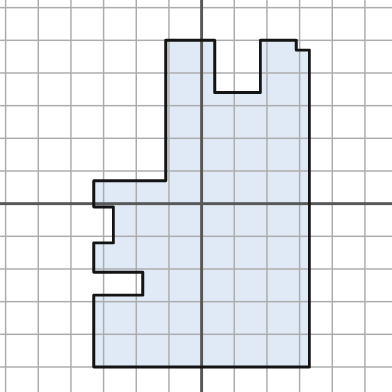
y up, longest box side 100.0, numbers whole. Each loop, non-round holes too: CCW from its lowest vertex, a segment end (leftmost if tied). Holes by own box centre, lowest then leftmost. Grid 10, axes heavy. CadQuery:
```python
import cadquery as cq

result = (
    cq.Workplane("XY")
    .moveTo(-33.0, -50.0)
    .lineTo(33.0, -50.0)
    .lineTo(33.0, 47.0)
    .lineTo(29.0, 47.0)
    .lineTo(29.0, 50.0)
    .lineTo(18.0, 50.0)
    .lineTo(18.0, 34.0)
    .lineTo(4.0, 34.0)
    .lineTo(4.0, 50.0)
    .lineTo(-11.0, 50.0)
    .lineTo(-11.0, 7.0)
    .lineTo(-33.0, 7.0)
    .lineTo(-33.0, -1.0)
    .lineTo(-27.0, -1.0)
    .lineTo(-27.0, -12.0)
    .lineTo(-33.0, -12.0)
    .lineTo(-33.0, -21.0)
    .lineTo(-18.0, -21.0)
    .lineTo(-18.0, -28.0)
    .lineTo(-33.0, -28.0)
    .close()
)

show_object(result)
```